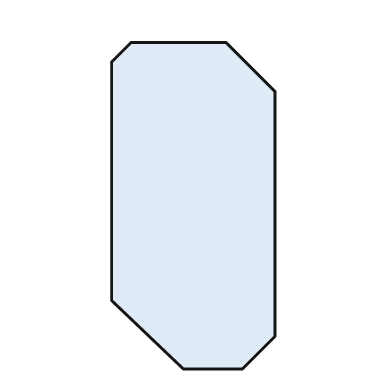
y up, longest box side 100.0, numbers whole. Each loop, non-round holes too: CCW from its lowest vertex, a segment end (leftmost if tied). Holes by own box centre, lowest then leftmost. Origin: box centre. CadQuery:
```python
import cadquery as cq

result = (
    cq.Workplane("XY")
    .moveTo(-3.0, -50.0)
    .lineTo(15.0, -50.0)
    .lineTo(25.0, -40.0)
    .lineTo(25.0, 35.0)
    .lineTo(10.0, 50.0)
    .lineTo(-19.0, 50.0)
    .lineTo(-25.0, 44.0)
    .lineTo(-25.0, -29.0)
    .close()
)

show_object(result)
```